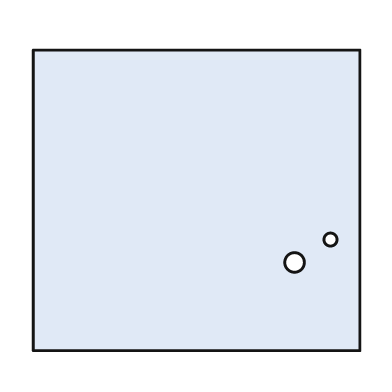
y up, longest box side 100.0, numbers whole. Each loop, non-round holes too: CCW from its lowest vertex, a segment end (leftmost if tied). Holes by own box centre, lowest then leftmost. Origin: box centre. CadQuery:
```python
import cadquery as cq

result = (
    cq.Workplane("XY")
    .moveTo(-50.0, -46.0)
    .lineTo(50.0, -46.0)
    .lineTo(50.0, 46.0)
    .lineTo(-50.0, 46.0)
    .close()
    .moveTo(30.0, -19.0)
    .circle(3.0)
    .moveTo(41.0, -12.0)
    .circle(2.0)
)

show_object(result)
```